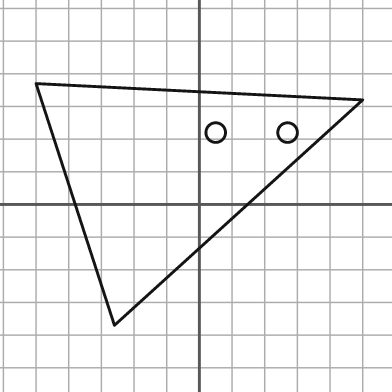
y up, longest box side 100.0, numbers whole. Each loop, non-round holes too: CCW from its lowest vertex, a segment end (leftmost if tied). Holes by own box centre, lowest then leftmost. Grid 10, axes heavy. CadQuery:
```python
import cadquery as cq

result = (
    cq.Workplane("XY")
    .moveTo(-26.0, -37.0)
    .lineTo(50.0, 32.0)
    .lineTo(-50.0, 37.0)
    .close()
    .moveTo(5.0, 22.0)
    .circle(3.0)
    .moveTo(27.0, 22.0)
    .circle(3.0)
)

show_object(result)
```